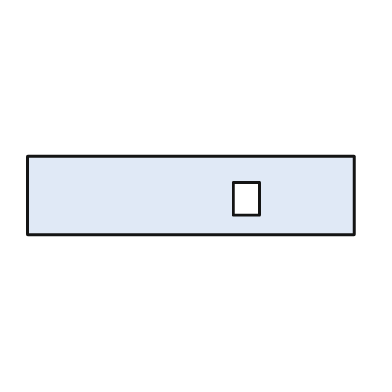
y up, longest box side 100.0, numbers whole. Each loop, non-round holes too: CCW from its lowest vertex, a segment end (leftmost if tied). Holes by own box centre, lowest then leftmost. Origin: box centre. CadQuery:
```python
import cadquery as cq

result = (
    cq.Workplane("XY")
    .moveTo(-50.0, -12.0)
    .lineTo(50.0, -12.0)
    .lineTo(50.0, 12.0)
    .lineTo(-50.0, 12.0)
    .close()
    .moveTo(13.0, -6.0)
    .lineTo(21.0, -6.0)
    .lineTo(21.0, 4.0)
    .lineTo(13.0, 4.0)
    .close()
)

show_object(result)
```